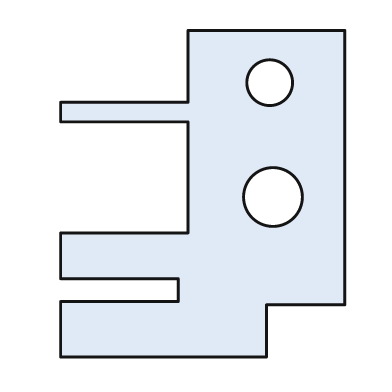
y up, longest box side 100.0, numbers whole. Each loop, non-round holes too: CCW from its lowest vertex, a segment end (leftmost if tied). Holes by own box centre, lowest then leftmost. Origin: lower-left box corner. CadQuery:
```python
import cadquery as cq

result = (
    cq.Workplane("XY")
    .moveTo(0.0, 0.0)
    .lineTo(63.0, 0.0)
    .lineTo(63.0, 16.0)
    .lineTo(87.0, 16.0)
    .lineTo(87.0, 100.0)
    .lineTo(39.0, 100.0)
    .lineTo(39.0, 78.0)
    .lineTo(0.0, 78.0)
    .lineTo(0.0, 72.0)
    .lineTo(39.0, 72.0)
    .lineTo(39.0, 38.0)
    .lineTo(0.0, 38.0)
    .lineTo(0.0, 24.0)
    .lineTo(36.0, 24.0)
    .lineTo(36.0, 17.0)
    .lineTo(0.0, 17.0)
    .close()
    .moveTo(65.0, 49.0)
    .circle(9.0)
    .moveTo(64.0, 84.0)
    .circle(7.0)
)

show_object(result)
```